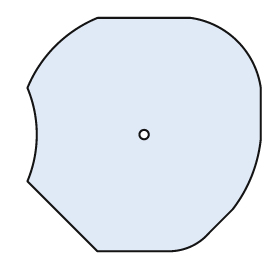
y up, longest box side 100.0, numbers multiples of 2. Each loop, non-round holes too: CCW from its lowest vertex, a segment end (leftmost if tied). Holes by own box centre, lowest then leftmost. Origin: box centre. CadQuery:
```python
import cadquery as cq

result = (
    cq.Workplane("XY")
    .moveTo(-20.0, -50.0)
    .lineTo(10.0, -50.0)
    .threePointArc((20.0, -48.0), (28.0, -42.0))
    .lineTo(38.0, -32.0)
    .threePointArc((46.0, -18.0), (50.0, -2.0))
    .lineTo(50.0, 20.0)
    .threePointArc((40.0, 40.0), (20.0, 50.0))
    .lineTo(-20.0, 50.0)
    .threePointArc((-38.0, 38.0), (-50.0, 20.0))
    .threePointArc((-46.0, 0.0), (-50.0, -20.0))
    .close()
    .moveTo(0.0, 0.0)
    .circle(2.0)
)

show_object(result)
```